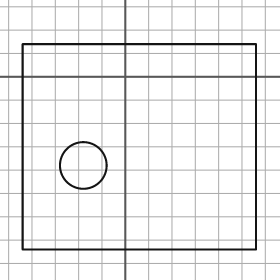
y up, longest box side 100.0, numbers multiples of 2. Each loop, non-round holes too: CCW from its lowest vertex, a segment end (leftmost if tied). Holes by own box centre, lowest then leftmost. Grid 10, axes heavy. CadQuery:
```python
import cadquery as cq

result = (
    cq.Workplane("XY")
    .moveTo(-44.0, -74.0)
    .lineTo(56.0, -74.0)
    .lineTo(56.0, 14.0)
    .lineTo(-44.0, 14.0)
    .close()
    .moveTo(-18.0, -38.0)
    .circle(10.0)
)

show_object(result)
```